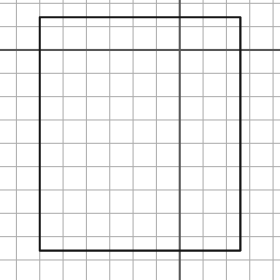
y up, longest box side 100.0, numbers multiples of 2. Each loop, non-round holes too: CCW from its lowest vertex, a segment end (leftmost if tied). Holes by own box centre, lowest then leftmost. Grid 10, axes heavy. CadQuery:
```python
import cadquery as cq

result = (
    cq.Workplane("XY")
    .moveTo(-60.0, -86.0)
    .lineTo(26.0, -86.0)
    .lineTo(26.0, 14.0)
    .lineTo(-60.0, 14.0)
    .close()
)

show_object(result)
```